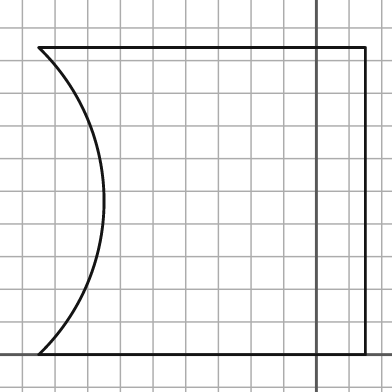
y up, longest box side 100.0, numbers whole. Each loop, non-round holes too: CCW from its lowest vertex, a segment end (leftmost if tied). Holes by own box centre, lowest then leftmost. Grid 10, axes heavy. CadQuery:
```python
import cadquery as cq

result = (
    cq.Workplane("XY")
    .moveTo(-85.0, 0.0)
    .lineTo(15.0, 0.0)
    .lineTo(15.0, 94.0)
    .lineTo(-85.0, 94.0)
    .threePointArc((-65.0, 47.0), (-85.0, 0.0))
    .close()
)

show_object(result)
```